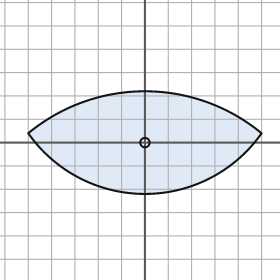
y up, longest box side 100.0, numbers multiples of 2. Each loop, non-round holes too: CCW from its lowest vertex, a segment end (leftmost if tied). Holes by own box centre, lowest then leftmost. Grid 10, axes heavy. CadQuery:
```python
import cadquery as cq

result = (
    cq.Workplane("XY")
    .moveTo(-50.0, 4.0)
    .threePointArc((0.0, -22.0), (50.0, 4.0))
    .threePointArc((0.0, 22.0), (-50.0, 4.0))
    .close()
    .moveTo(0.0, 0.0)
    .circle(2.0)
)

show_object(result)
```